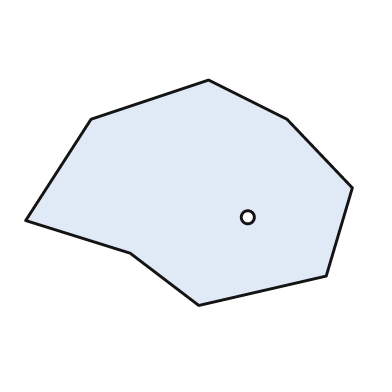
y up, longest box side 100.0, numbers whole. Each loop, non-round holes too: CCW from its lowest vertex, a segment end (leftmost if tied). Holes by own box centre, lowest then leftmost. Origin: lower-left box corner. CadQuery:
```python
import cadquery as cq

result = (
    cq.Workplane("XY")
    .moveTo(53.0, 0.0)
    .lineTo(92.0, 9.0)
    .lineTo(100.0, 36.0)
    .lineTo(80.0, 57.0)
    .lineTo(56.0, 69.0)
    .lineTo(20.0, 57.0)
    .lineTo(0.0, 26.0)
    .lineTo(32.0, 16.0)
    .close()
    .moveTo(68.0, 27.0)
    .circle(2.0)
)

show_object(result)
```